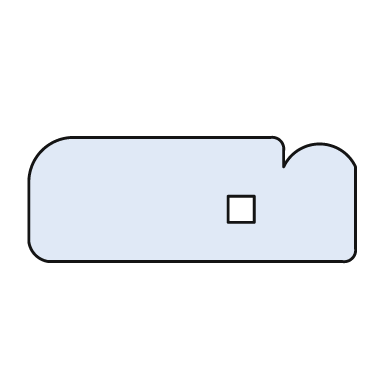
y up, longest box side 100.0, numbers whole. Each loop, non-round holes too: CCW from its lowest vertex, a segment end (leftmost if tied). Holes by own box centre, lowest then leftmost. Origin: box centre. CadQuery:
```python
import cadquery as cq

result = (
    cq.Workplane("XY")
    .moveTo(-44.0, -19.0)
    .lineTo(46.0, -19.0)
    .threePointArc((49.0, -18.0), (50.0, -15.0))
    .lineTo(50.0, 10.0)
    .threePointArc((39.0, 17.0), (28.0, 10.0))
    .lineTo(28.0, 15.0)
    .threePointArc((27.0, 18.0), (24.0, 19.0))
    .lineTo(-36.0, 19.0)
    .threePointArc((-46.0, 15.0), (-50.0, 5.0))
    .lineTo(-50.0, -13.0)
    .threePointArc((-48.0, -17.0), (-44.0, -19.0))
    .close()
    .moveTo(11.0, -7.0)
    .lineTo(19.0, -7.0)
    .lineTo(19.0, 1.0)
    .lineTo(11.0, 1.0)
    .close()
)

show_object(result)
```